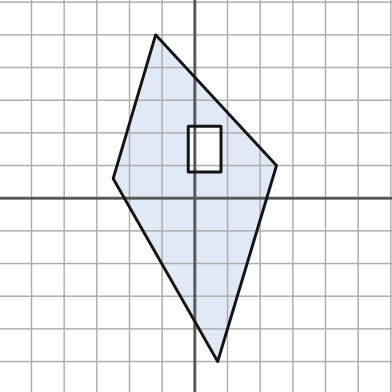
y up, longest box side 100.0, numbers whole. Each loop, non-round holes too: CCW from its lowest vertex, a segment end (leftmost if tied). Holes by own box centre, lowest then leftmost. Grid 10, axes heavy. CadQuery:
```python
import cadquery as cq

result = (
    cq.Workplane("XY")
    .moveTo(7.0, -50.0)
    .lineTo(25.0, 10.0)
    .lineTo(-12.0, 50.0)
    .lineTo(-25.0, 6.0)
    .close()
    .moveTo(-2.0, 8.0)
    .lineTo(8.0, 8.0)
    .lineTo(8.0, 22.0)
    .lineTo(-2.0, 22.0)
    .close()
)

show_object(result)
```